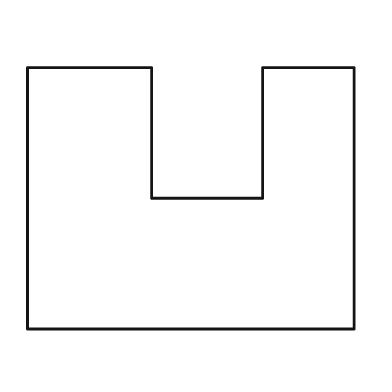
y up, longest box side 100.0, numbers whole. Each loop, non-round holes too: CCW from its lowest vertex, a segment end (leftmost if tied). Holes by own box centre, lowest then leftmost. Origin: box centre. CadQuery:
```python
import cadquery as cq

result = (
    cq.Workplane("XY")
    .moveTo(-50.0, -40.0)
    .lineTo(50.0, -40.0)
    .lineTo(50.0, 40.0)
    .lineTo(22.0, 40.0)
    .lineTo(22.0, 0.0)
    .lineTo(-12.0, 0.0)
    .lineTo(-12.0, 40.0)
    .lineTo(-50.0, 40.0)
    .close()
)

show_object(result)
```